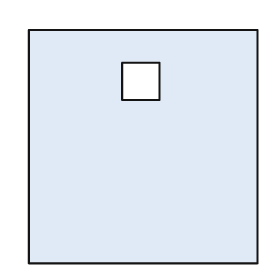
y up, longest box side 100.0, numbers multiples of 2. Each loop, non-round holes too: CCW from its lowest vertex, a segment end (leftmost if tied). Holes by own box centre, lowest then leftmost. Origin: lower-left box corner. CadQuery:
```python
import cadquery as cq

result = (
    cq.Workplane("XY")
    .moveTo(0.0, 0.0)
    .lineTo(98.0, 0.0)
    .lineTo(98.0, 100.0)
    .lineTo(0.0, 100.0)
    .close()
    .moveTo(40.0, 70.0)
    .lineTo(56.0, 70.0)
    .lineTo(56.0, 86.0)
    .lineTo(40.0, 86.0)
    .close()
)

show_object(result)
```